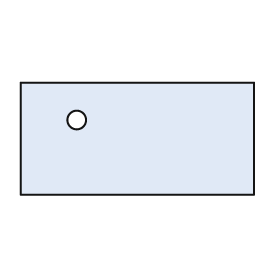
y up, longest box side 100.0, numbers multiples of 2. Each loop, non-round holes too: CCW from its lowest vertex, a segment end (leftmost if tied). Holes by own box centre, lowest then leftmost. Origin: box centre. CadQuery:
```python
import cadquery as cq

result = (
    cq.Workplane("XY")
    .moveTo(-50.0, -24.0)
    .lineTo(50.0, -24.0)
    .lineTo(50.0, 24.0)
    .lineTo(-50.0, 24.0)
    .close()
    .moveTo(-26.0, 8.0)
    .circle(4.0)
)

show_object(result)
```